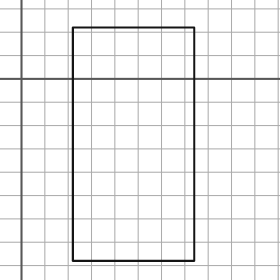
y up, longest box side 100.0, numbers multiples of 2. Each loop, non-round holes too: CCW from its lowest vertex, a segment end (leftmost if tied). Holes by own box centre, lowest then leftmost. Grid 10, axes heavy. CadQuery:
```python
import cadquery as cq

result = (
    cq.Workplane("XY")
    .moveTo(22.0, -78.0)
    .lineTo(74.0, -78.0)
    .lineTo(74.0, 22.0)
    .lineTo(22.0, 22.0)
    .close()
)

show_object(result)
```